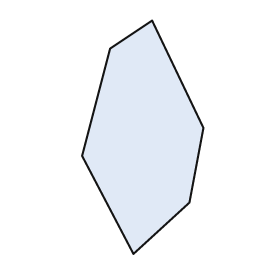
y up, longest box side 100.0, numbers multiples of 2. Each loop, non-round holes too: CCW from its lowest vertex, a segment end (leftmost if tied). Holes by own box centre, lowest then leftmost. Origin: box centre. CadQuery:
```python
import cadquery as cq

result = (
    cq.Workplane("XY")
    .moveTo(-4.0, -50.0)
    .lineTo(20.0, -28.0)
    .lineTo(26.0, 4.0)
    .lineTo(4.0, 50.0)
    .lineTo(-14.0, 38.0)
    .lineTo(-26.0, -8.0)
    .close()
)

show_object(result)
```